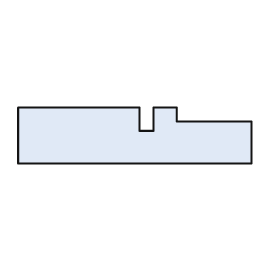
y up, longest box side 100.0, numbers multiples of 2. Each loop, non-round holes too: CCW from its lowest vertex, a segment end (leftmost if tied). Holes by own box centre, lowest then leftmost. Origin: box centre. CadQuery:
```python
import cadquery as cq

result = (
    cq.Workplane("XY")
    .moveTo(-50.0, -12.0)
    .lineTo(50.0, -12.0)
    .lineTo(50.0, 6.0)
    .lineTo(18.0, 6.0)
    .lineTo(18.0, 12.0)
    .lineTo(8.0, 12.0)
    .lineTo(8.0, 2.0)
    .lineTo(2.0, 2.0)
    .lineTo(2.0, 12.0)
    .lineTo(-50.0, 12.0)
    .close()
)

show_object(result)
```